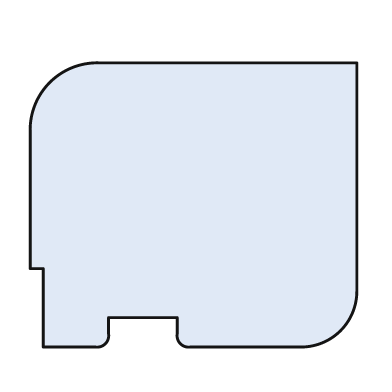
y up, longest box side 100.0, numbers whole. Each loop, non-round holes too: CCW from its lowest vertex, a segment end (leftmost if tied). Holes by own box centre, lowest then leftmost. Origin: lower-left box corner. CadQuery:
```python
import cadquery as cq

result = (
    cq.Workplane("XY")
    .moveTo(4.0, 0.0)
    .lineTo(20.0, 0.0)
    .threePointArc((23.0, 1.0), (24.0, 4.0))
    .lineTo(24.0, 9.0)
    .lineTo(45.0, 9.0)
    .lineTo(45.0, 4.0)
    .threePointArc((46.0, 1.0), (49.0, 0.0))
    .lineTo(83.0, 0.0)
    .threePointArc((95.0, 5.0), (100.0, 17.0))
    .lineTo(100.0, 87.0)
    .lineTo(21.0, 87.0)
    .threePointArc((6.0, 81.0), (0.0, 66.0))
    .lineTo(0.0, 24.0)
    .lineTo(4.0, 24.0)
    .close()
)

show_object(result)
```